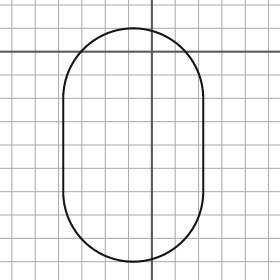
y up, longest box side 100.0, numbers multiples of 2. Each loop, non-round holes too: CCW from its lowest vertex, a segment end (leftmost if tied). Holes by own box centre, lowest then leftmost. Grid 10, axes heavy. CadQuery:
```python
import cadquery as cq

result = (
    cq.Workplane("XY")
    .moveTo(-38.0, -60.0)
    .threePointArc((-8.0, -90.0), (22.0, -60.0))
    .lineTo(22.0, -20.0)
    .threePointArc((-8.0, 10.0), (-38.0, -20.0))
    .close()
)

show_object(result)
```